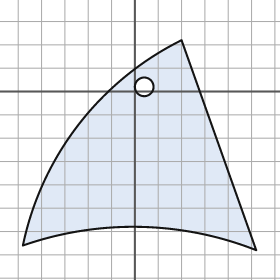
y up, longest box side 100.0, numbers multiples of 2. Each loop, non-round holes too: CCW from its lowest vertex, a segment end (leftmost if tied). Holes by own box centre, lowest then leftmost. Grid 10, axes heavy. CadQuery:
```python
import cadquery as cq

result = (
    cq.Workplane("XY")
    .moveTo(52.0, -68.0)
    .lineTo(20.0, 22.0)
    .threePointArc((-24.0, -14.0), (-48.0, -66.0))
    .threePointArc((2.0, -58.0), (52.0, -68.0))
    .close()
    .moveTo(4.0, 2.0)
    .circle(4.0)
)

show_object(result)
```